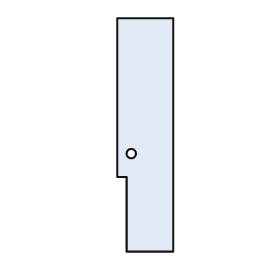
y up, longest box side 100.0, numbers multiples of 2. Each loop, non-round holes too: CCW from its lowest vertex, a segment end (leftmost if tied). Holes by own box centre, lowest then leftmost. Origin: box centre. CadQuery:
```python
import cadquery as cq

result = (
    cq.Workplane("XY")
    .moveTo(-8.0, -50.0)
    .lineTo(12.0, -50.0)
    .lineTo(12.0, 50.0)
    .lineTo(-12.0, 50.0)
    .lineTo(-12.0, -18.0)
    .lineTo(-8.0, -18.0)
    .close()
    .moveTo(-6.0, -8.0)
    .circle(2.0)
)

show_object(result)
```